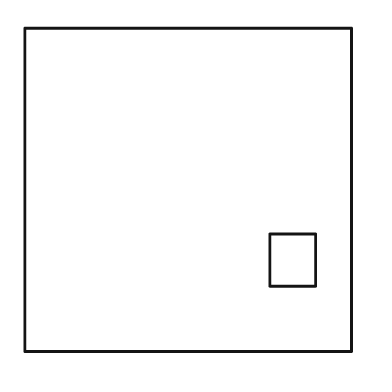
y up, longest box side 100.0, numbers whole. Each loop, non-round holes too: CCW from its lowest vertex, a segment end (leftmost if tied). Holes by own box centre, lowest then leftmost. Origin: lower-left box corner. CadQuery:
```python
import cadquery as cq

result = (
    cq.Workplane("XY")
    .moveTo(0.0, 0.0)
    .lineTo(100.0, 0.0)
    .lineTo(100.0, 99.0)
    .lineTo(0.0, 99.0)
    .close()
    .moveTo(75.0, 20.0)
    .lineTo(89.0, 20.0)
    .lineTo(89.0, 36.0)
    .lineTo(75.0, 36.0)
    .close()
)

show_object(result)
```